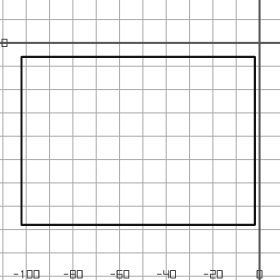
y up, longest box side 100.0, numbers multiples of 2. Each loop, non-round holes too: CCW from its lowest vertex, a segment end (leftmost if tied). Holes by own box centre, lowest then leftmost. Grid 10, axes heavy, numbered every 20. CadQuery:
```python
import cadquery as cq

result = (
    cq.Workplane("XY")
    .moveTo(-102.0, -78.0)
    .lineTo(-2.0, -78.0)
    .lineTo(-2.0, -6.0)
    .lineTo(-102.0, -6.0)
    .close()
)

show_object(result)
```